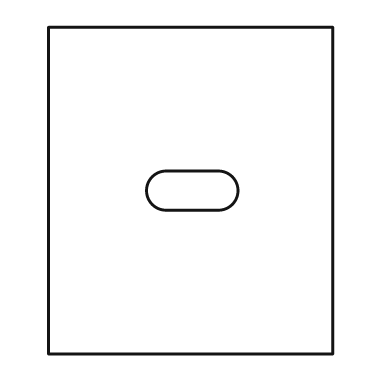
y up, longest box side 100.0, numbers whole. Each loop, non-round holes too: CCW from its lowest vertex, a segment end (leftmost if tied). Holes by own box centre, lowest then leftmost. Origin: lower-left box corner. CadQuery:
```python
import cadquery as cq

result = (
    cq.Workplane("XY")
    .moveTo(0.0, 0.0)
    .lineTo(87.0, 0.0)
    .lineTo(87.0, 100.0)
    .lineTo(0.0, 100.0)
    .close()
    .moveTo(36.0, 44.0)
    .lineTo(52.0, 44.0)
    .threePointArc((58.0, 50.0), (52.0, 56.0))
    .lineTo(36.0, 56.0)
    .threePointArc((30.0, 50.0), (36.0, 44.0))
    .close()
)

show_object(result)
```